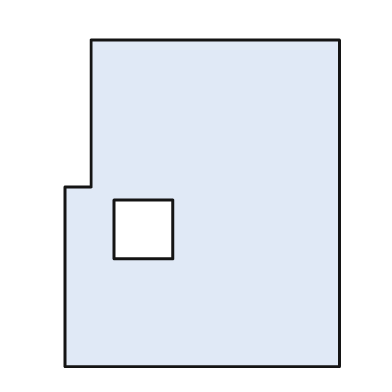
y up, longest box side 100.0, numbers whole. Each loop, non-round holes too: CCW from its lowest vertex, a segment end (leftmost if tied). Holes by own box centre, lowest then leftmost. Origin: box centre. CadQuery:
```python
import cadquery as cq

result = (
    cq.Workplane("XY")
    .moveTo(-42.0, -50.0)
    .lineTo(42.0, -50.0)
    .lineTo(42.0, 50.0)
    .lineTo(-34.0, 50.0)
    .lineTo(-34.0, 5.0)
    .lineTo(-42.0, 5.0)
    .close()
    .moveTo(-27.0, -17.0)
    .lineTo(-9.0, -17.0)
    .lineTo(-9.0, 1.0)
    .lineTo(-27.0, 1.0)
    .close()
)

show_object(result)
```